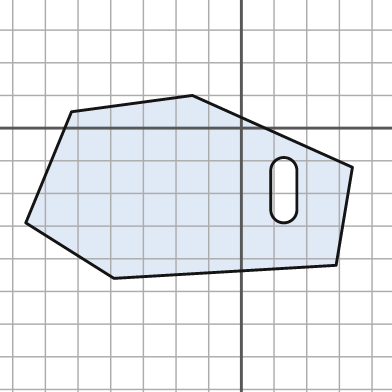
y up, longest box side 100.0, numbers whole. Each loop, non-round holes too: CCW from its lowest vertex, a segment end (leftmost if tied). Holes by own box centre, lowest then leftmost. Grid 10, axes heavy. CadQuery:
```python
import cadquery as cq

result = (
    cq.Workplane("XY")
    .moveTo(-39.0, -46.0)
    .lineTo(29.0, -42.0)
    .lineTo(34.0, -12.0)
    .lineTo(-15.0, 10.0)
    .lineTo(-52.0, 5.0)
    .lineTo(-66.0, -29.0)
    .close()
    .moveTo(9.0, -25.0)
    .threePointArc((13.0, -29.0), (17.0, -25.0))
    .lineTo(17.0, -13.0)
    .threePointArc((13.0, -9.0), (9.0, -13.0))
    .close()
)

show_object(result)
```